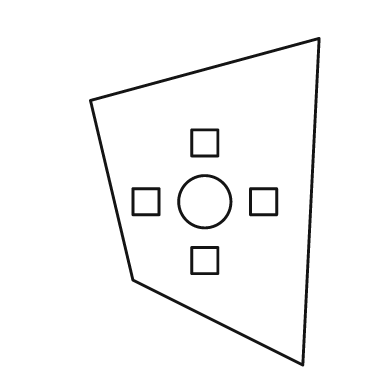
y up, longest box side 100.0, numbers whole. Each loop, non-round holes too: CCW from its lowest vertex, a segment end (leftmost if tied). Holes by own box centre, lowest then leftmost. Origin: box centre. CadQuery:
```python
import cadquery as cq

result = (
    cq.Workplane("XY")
    .moveTo(30.0, -50.0)
    .lineTo(35.0, 50.0)
    .lineTo(-35.0, 31.0)
    .lineTo(-22.0, -24.0)
    .close()
    .moveTo(-4.0, -22.0)
    .lineTo(4.0, -22.0)
    .lineTo(4.0, -14.0)
    .lineTo(-4.0, -14.0)
    .close()
    .moveTo(-22.0, -4.0)
    .lineTo(-14.0, -4.0)
    .lineTo(-14.0, 4.0)
    .lineTo(-22.0, 4.0)
    .close()
    .moveTo(0.0, 0.0)
    .circle(8.0)
    .moveTo(14.0, -4.0)
    .lineTo(22.0, -4.0)
    .lineTo(22.0, 4.0)
    .lineTo(14.0, 4.0)
    .close()
    .moveTo(-4.0, 14.0)
    .lineTo(4.0, 14.0)
    .lineTo(4.0, 22.0)
    .lineTo(-4.0, 22.0)
    .close()
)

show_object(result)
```